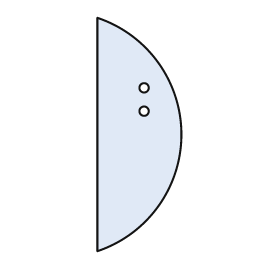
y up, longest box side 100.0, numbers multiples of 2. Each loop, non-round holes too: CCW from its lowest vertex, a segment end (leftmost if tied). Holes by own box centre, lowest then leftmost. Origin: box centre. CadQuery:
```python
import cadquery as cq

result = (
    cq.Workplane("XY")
    .moveTo(-18.0, -50.0)
    .threePointArc((18.0, 0.0), (-18.0, 50.0))
    .close()
    .moveTo(2.0, 10.0)
    .circle(2.0)
    .moveTo(2.0, 20.0)
    .circle(2.0)
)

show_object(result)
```